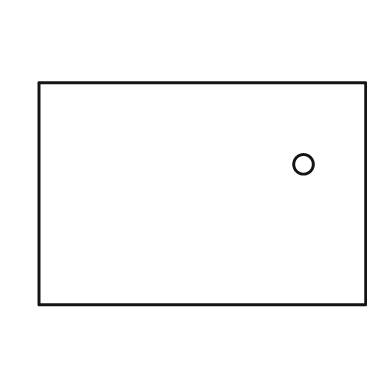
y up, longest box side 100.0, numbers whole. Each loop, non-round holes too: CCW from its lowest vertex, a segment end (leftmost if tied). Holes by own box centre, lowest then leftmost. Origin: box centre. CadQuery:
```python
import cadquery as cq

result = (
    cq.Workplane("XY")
    .moveTo(-50.0, -34.0)
    .lineTo(50.0, -34.0)
    .lineTo(50.0, 34.0)
    .lineTo(-50.0, 34.0)
    .close()
    .moveTo(31.0, 9.0)
    .circle(3.0)
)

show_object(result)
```